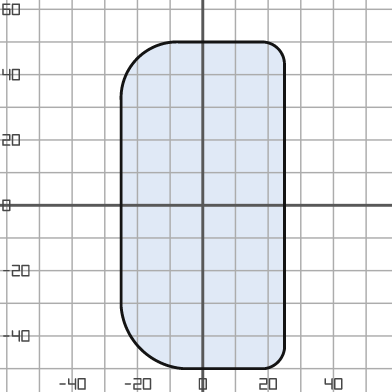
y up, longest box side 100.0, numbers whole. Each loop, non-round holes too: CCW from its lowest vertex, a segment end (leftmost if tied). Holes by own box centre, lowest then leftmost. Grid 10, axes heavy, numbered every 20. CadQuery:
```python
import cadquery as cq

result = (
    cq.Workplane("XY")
    .moveTo(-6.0, -50.0)
    .lineTo(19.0, -50.0)
    .threePointArc((23.0, -48.0), (25.0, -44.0))
    .lineTo(25.0, 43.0)
    .threePointArc((23.0, 48.0), (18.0, 50.0))
    .lineTo(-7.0, 50.0)
    .threePointArc((-20.0, 45.0), (-25.0, 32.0))
    .lineTo(-25.0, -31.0)
    .threePointArc((-19.0, -44.0), (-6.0, -50.0))
    .close()
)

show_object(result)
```